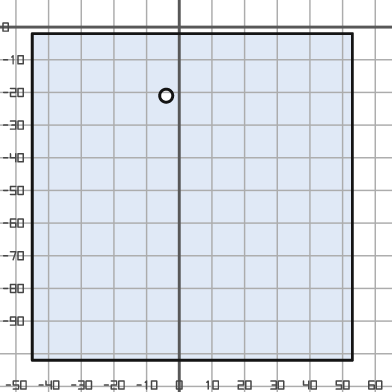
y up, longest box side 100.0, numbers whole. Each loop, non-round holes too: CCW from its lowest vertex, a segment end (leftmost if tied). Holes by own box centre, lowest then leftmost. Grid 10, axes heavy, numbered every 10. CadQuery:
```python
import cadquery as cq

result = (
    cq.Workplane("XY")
    .moveTo(-45.0, -102.0)
    .lineTo(53.0, -102.0)
    .lineTo(53.0, -2.0)
    .lineTo(-45.0, -2.0)
    .close()
    .moveTo(-4.0, -21.0)
    .circle(2.0)
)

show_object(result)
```